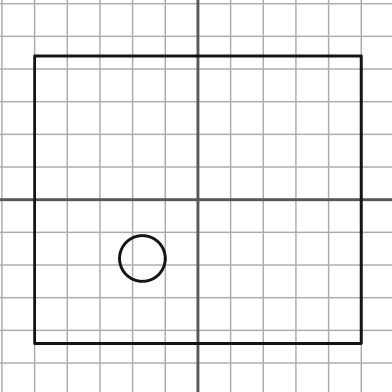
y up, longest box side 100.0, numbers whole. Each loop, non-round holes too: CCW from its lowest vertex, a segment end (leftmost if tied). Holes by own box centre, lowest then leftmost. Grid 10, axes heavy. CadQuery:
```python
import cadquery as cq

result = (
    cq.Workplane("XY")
    .moveTo(-50.0, -44.0)
    .lineTo(50.0, -44.0)
    .lineTo(50.0, 44.0)
    .lineTo(-50.0, 44.0)
    .close()
    .moveTo(-17.0, -18.0)
    .circle(7.0)
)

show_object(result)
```